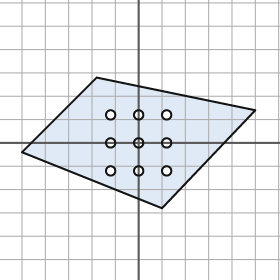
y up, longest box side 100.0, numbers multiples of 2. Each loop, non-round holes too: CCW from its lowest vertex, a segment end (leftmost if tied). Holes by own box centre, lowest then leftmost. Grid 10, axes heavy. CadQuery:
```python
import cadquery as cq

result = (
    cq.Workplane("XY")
    .moveTo(10.0, -28.0)
    .lineTo(50.0, 14.0)
    .lineTo(-18.0, 28.0)
    .lineTo(-50.0, -4.0)
    .close()
    .moveTo(-12.0, -12.0)
    .circle(2.0)
    .moveTo(0.0, -12.0)
    .circle(2.0)
    .moveTo(12.0, -12.0)
    .circle(2.0)
    .moveTo(-12.0, 0.0)
    .circle(2.0)
    .moveTo(0.0, 0.0)
    .circle(2.0)
    .moveTo(12.0, 0.0)
    .circle(2.0)
    .moveTo(-12.0, 12.0)
    .circle(2.0)
    .moveTo(0.0, 12.0)
    .circle(2.0)
    .moveTo(12.0, 12.0)
    .circle(2.0)
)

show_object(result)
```